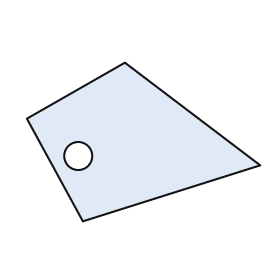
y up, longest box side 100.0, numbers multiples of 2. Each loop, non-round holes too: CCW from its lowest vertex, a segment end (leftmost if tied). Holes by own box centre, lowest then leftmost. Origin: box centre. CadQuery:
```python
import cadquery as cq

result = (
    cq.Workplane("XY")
    .moveTo(-26.0, -34.0)
    .lineTo(50.0, -10.0)
    .lineTo(-8.0, 34.0)
    .lineTo(-50.0, 10.0)
    .close()
    .moveTo(-28.0, -6.0)
    .circle(6.0)
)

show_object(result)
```